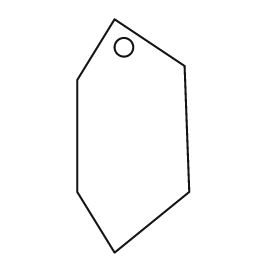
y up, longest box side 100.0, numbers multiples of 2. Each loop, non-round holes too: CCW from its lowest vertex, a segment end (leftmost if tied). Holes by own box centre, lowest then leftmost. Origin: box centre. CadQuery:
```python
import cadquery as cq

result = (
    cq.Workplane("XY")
    .moveTo(-8.0, -50.0)
    .lineTo(24.0, -24.0)
    .lineTo(22.0, 30.0)
    .lineTo(-8.0, 50.0)
    .lineTo(-24.0, 24.0)
    .lineTo(-24.0, -24.0)
    .close()
    .moveTo(-4.0, 38.0)
    .circle(4.0)
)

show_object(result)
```